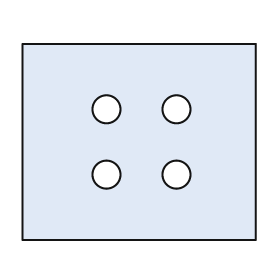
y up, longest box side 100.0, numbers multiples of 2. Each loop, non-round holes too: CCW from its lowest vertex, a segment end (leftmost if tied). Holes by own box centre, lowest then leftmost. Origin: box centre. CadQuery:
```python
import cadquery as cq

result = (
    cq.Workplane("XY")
    .moveTo(-50.0, -42.0)
    .lineTo(50.0, -42.0)
    .lineTo(50.0, 42.0)
    .lineTo(-50.0, 42.0)
    .close()
    .moveTo(-14.0, -14.0)
    .circle(6.0)
    .moveTo(16.0, -14.0)
    .circle(6.0)
    .moveTo(-14.0, 14.0)
    .circle(6.0)
    .moveTo(16.0, 14.0)
    .circle(6.0)
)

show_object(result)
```